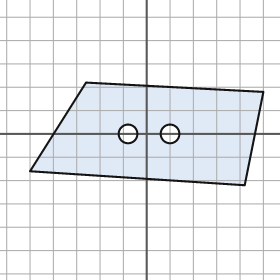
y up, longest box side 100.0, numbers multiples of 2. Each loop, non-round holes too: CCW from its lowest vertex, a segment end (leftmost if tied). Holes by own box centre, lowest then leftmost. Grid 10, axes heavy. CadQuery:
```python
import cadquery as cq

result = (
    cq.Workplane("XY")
    .moveTo(42.0, -22.0)
    .lineTo(50.0, 18.0)
    .lineTo(-26.0, 22.0)
    .lineTo(-50.0, -16.0)
    .close()
    .moveTo(-8.0, 0.0)
    .circle(4.0)
    .moveTo(10.0, 0.0)
    .circle(4.0)
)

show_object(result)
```